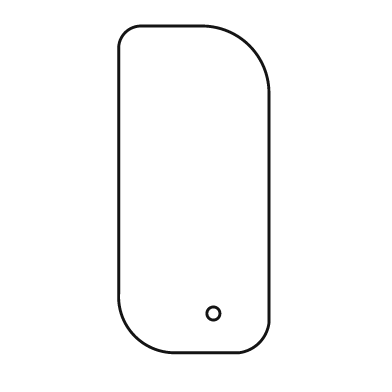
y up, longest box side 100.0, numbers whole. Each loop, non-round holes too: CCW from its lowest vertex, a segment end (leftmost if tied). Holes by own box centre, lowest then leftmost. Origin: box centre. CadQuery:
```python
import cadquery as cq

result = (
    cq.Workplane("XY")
    .moveTo(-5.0, -50.0)
    .lineTo(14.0, -50.0)
    .threePointArc((20.0, -47.0), (23.0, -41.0))
    .lineTo(23.0, 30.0)
    .threePointArc((17.0, 44.0), (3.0, 50.0))
    .lineTo(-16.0, 50.0)
    .threePointArc((-21.0, 48.0), (-23.0, 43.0))
    .lineTo(-23.0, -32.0)
    .threePointArc((-18.0, -45.0), (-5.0, -50.0))
    .close()
    .moveTo(6.0, -38.0)
    .circle(2.0)
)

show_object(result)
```